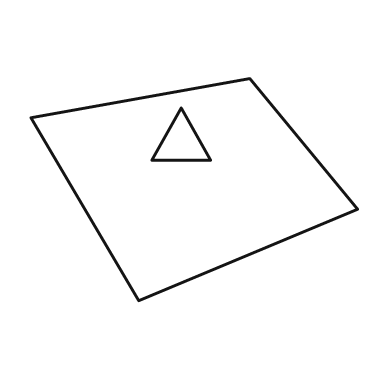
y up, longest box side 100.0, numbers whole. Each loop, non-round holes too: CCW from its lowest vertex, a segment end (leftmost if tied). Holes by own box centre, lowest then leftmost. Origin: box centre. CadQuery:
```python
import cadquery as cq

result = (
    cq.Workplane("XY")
    .moveTo(-17.0, -34.0)
    .lineTo(50.0, -6.0)
    .lineTo(17.0, 34.0)
    .lineTo(-50.0, 22.0)
    .close()
    .moveTo(-13.0, 9.0)
    .lineTo(5.0, 9.0)
    .lineTo(-4.0, 25.0)
    .close()
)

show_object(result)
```